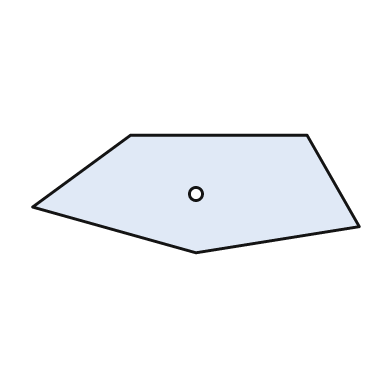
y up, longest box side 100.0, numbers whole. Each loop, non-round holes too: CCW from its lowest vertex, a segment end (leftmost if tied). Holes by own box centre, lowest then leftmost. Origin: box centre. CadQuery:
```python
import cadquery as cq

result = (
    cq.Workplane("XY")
    .moveTo(0.0, -18.0)
    .lineTo(50.0, -10.0)
    .lineTo(34.0, 18.0)
    .lineTo(-20.0, 18.0)
    .lineTo(-50.0, -4.0)
    .close()
    .moveTo(0.0, 0.0)
    .circle(2.0)
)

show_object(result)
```